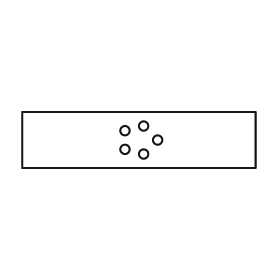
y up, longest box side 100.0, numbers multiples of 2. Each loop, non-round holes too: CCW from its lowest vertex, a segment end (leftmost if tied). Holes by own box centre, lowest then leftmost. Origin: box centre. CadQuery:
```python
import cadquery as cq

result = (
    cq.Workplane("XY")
    .moveTo(-50.0, -12.0)
    .lineTo(50.0, -12.0)
    .lineTo(50.0, 12.0)
    .lineTo(-50.0, 12.0)
    .close()
    .moveTo(2.0, -6.0)
    .circle(2.0)
    .moveTo(-6.0, -4.0)
    .circle(2.0)
    .moveTo(8.0, 0.0)
    .circle(2.0)
    .moveTo(-6.0, 4.0)
    .circle(2.0)
    .moveTo(2.0, 6.0)
    .circle(2.0)
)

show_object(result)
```